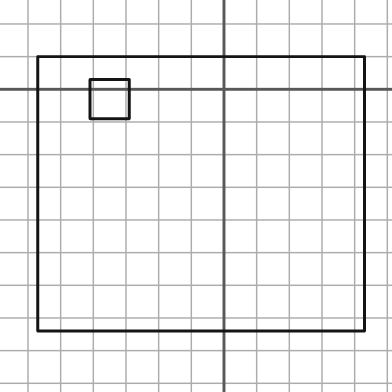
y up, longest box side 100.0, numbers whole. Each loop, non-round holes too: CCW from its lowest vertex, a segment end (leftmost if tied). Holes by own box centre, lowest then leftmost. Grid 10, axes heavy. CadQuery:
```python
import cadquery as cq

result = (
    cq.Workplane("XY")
    .moveTo(-57.0, -74.0)
    .lineTo(43.0, -74.0)
    .lineTo(43.0, 10.0)
    .lineTo(-57.0, 10.0)
    .close()
    .moveTo(-41.0, -9.0)
    .lineTo(-29.0, -9.0)
    .lineTo(-29.0, 3.0)
    .lineTo(-41.0, 3.0)
    .close()
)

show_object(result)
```